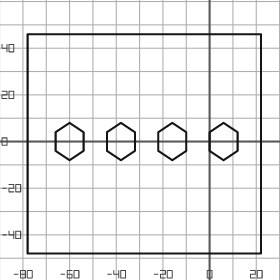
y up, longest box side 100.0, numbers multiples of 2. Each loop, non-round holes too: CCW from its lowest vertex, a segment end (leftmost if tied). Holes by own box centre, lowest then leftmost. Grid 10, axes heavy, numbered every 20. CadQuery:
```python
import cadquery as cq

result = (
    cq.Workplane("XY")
    .moveTo(-78.0, -48.0)
    .lineTo(22.0, -48.0)
    .lineTo(22.0, 46.0)
    .lineTo(-78.0, 46.0)
    .close()
    .moveTo(-60.0, -8.0)
    .lineTo(-54.0, -4.0)
    .lineTo(-54.0, 4.0)
    .lineTo(-60.0, 8.0)
    .lineTo(-66.0, 4.0)
    .lineTo(-66.0, -4.0)
    .close()
    .moveTo(-38.0, -8.0)
    .lineTo(-32.0, -4.0)
    .lineTo(-32.0, 4.0)
    .lineTo(-38.0, 8.0)
    .lineTo(-44.0, 4.0)
    .lineTo(-44.0, -4.0)
    .close()
    .moveTo(-16.0, -8.0)
    .lineTo(-10.0, -4.0)
    .lineTo(-10.0, 4.0)
    .lineTo(-16.0, 8.0)
    .lineTo(-22.0, 4.0)
    .lineTo(-22.0, -4.0)
    .close()
    .moveTo(6.0, -8.0)
    .lineTo(12.0, -4.0)
    .lineTo(12.0, 4.0)
    .lineTo(6.0, 8.0)
    .lineTo(0.0, 4.0)
    .lineTo(0.0, -4.0)
    .close()
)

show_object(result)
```